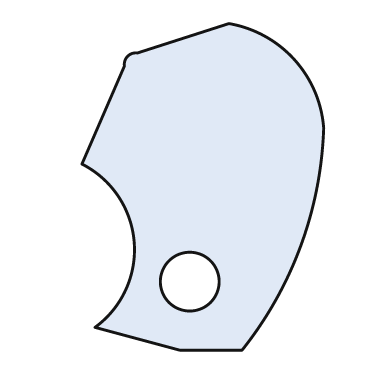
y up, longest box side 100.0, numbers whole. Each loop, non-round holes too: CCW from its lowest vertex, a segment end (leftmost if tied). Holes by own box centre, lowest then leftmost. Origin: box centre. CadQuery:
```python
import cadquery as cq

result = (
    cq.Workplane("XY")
    .moveTo(-7.0, -50.0)
    .lineTo(12.0, -50.0)
    .threePointArc((30.0, -18.0), (37.0, 18.0))
    .threePointArc((28.0, 39.0), (8.0, 50.0))
    .lineTo(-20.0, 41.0)
    .threePointArc((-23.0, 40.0), (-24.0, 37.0))
    .lineTo(-37.0, 7.0)
    .threePointArc((-21.0, -17.0), (-33.0, -43.0))
    .close()
    .moveTo(-4.0, -29.0)
    .circle(9.0)
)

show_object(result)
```